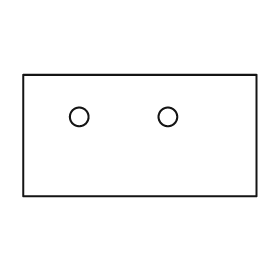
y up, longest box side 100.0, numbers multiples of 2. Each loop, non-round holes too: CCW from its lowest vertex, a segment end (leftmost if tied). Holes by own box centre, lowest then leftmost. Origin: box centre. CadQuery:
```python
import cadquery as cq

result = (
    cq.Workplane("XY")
    .moveTo(-50.0, -26.0)
    .lineTo(50.0, -26.0)
    .lineTo(50.0, 26.0)
    .lineTo(-50.0, 26.0)
    .close()
    .moveTo(-26.0, 8.0)
    .circle(4.0)
    .moveTo(12.0, 8.0)
    .circle(4.0)
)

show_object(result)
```